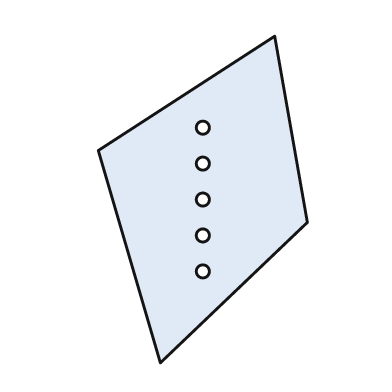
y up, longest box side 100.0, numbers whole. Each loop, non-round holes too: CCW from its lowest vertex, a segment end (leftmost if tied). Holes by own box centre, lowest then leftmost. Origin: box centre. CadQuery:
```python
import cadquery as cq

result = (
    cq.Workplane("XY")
    .moveTo(-13.0, -50.0)
    .lineTo(32.0, -7.0)
    .lineTo(22.0, 50.0)
    .lineTo(-32.0, 15.0)
    .close()
    .moveTo(0.0, -22.0)
    .circle(2.0)
    .moveTo(0.0, -11.0)
    .circle(2.0)
    .moveTo(0.0, 0.0)
    .circle(2.0)
    .moveTo(0.0, 11.0)
    .circle(2.0)
    .moveTo(0.0, 22.0)
    .circle(2.0)
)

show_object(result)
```